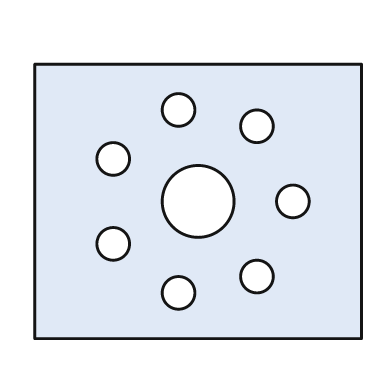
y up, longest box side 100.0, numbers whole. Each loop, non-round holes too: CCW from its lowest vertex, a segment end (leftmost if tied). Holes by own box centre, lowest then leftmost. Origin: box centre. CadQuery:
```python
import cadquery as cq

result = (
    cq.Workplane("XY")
    .moveTo(-50.0, -42.0)
    .lineTo(50.0, -42.0)
    .lineTo(50.0, 42.0)
    .lineTo(-50.0, 42.0)
    .close()
    .moveTo(-6.0, -28.0)
    .circle(5.0)
    .moveTo(18.0, -23.0)
    .circle(5.0)
    .moveTo(-26.0, -13.0)
    .circle(5.0)
    .moveTo(0.0, 0.0)
    .circle(11.0)
    .moveTo(29.0, 0.0)
    .circle(5.0)
    .moveTo(-26.0, 13.0)
    .circle(5.0)
    .moveTo(18.0, 23.0)
    .circle(5.0)
    .moveTo(-6.0, 28.0)
    .circle(5.0)
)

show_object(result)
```